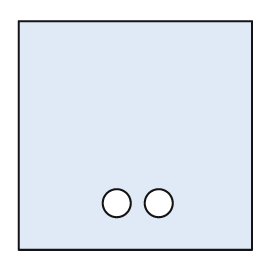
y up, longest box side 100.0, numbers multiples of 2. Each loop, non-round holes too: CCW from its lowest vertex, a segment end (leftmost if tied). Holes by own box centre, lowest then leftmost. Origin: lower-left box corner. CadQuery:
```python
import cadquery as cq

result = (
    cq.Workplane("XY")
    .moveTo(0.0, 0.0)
    .lineTo(100.0, 0.0)
    .lineTo(100.0, 98.0)
    .lineTo(0.0, 98.0)
    .close()
    .moveTo(42.0, 20.0)
    .circle(6.0)
    .moveTo(60.0, 20.0)
    .circle(6.0)
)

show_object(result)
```